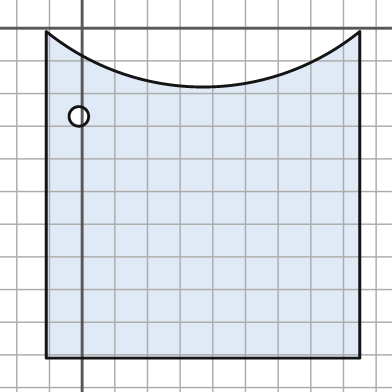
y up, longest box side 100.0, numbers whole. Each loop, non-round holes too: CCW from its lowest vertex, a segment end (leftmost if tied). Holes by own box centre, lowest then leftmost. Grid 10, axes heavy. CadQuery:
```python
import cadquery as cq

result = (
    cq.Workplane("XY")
    .moveTo(-11.0, -101.0)
    .lineTo(85.0, -101.0)
    .lineTo(85.0, -1.0)
    .threePointArc((37.0, -18.0), (-11.0, -1.0))
    .close()
    .moveTo(-1.0, -27.0)
    .circle(3.0)
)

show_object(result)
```